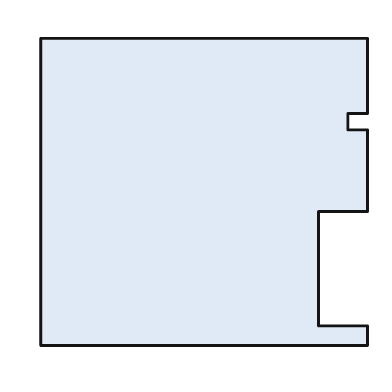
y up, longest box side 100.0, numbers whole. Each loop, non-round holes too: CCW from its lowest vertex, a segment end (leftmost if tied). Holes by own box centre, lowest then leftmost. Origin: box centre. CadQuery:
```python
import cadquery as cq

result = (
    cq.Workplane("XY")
    .moveTo(-50.0, -47.0)
    .lineTo(50.0, -47.0)
    .lineTo(50.0, -41.0)
    .lineTo(35.0, -41.0)
    .lineTo(35.0, -6.0)
    .lineTo(50.0, -6.0)
    .lineTo(50.0, 19.0)
    .lineTo(44.0, 19.0)
    .lineTo(44.0, 24.0)
    .lineTo(50.0, 24.0)
    .lineTo(50.0, 47.0)
    .lineTo(-50.0, 47.0)
    .close()
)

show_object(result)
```